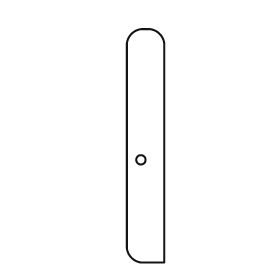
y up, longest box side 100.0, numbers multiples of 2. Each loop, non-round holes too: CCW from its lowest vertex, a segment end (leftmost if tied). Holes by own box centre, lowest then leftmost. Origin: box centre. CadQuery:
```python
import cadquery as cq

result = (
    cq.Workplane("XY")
    .moveTo(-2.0, -50.0)
    .lineTo(8.0, -50.0)
    .lineTo(8.0, 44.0)
    .threePointArc((6.0, 48.0), (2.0, 50.0))
    .lineTo(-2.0, 50.0)
    .threePointArc((-6.0, 48.0), (-8.0, 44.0))
    .lineTo(-8.0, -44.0)
    .threePointArc((-6.0, -48.0), (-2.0, -50.0))
    .close()
    .moveTo(-2.0, -6.0)
    .circle(2.0)
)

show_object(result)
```